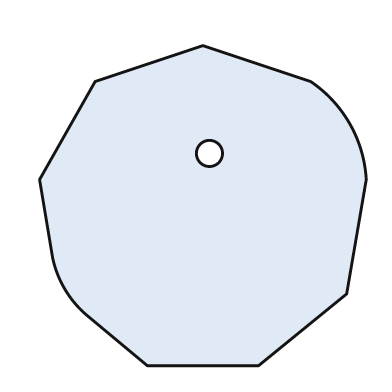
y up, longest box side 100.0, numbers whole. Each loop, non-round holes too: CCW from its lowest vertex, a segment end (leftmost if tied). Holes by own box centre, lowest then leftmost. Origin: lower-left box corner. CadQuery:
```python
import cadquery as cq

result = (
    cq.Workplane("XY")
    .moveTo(33.0, 0.0)
    .lineTo(67.0, 0.0)
    .lineTo(94.0, 22.0)
    .lineTo(100.0, 57.0)
    .threePointArc((95.0, 74.0), (83.0, 87.0))
    .lineTo(50.0, 98.0)
    .lineTo(17.0, 87.0)
    .lineTo(0.0, 57.0)
    .lineTo(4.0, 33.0)
    .threePointArc((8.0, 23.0), (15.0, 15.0))
    .close()
    .moveTo(52.0, 65.0)
    .circle(4.0)
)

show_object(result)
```